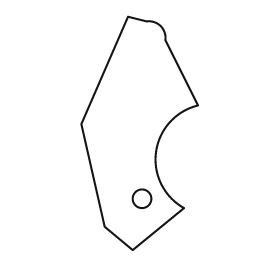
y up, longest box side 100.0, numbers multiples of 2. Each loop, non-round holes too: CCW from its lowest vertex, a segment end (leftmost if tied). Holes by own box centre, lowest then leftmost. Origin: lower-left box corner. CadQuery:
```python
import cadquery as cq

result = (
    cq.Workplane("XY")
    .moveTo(22.0, 0.0)
    .lineTo(44.0, 18.0)
    .threePointArc((32.0, 42.0), (50.0, 62.0))
    .lineTo(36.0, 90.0)
    .threePointArc((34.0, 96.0), (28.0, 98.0))
    .lineTo(20.0, 100.0)
    .lineTo(0.0, 54.0)
    .lineTo(10.0, 10.0)
    .close()
    .moveTo(26.0, 22.0)
    .circle(4.0)
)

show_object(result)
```